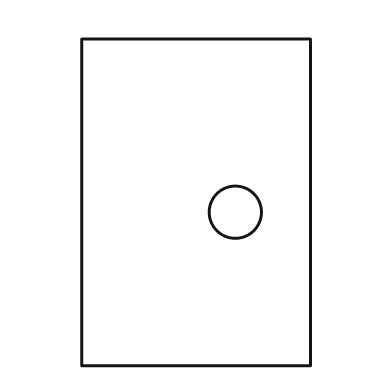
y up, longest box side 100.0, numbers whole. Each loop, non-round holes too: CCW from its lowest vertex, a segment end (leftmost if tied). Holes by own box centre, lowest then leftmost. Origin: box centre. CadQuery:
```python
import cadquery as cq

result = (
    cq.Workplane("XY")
    .moveTo(-35.0, -50.0)
    .lineTo(35.0, -50.0)
    .lineTo(35.0, 50.0)
    .lineTo(-35.0, 50.0)
    .close()
    .moveTo(12.0, -3.0)
    .circle(8.0)
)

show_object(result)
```